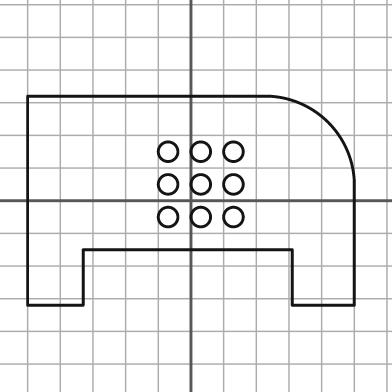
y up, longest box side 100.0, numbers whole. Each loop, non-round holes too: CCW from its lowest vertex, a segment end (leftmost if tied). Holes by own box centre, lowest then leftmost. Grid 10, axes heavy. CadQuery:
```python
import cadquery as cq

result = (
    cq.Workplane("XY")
    .moveTo(-50.0, -32.0)
    .lineTo(-33.0, -32.0)
    .lineTo(-33.0, -15.0)
    .lineTo(31.0, -15.0)
    .lineTo(31.0, -32.0)
    .lineTo(50.0, -32.0)
    .lineTo(50.0, 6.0)
    .threePointArc((42.0, 24.0), (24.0, 32.0))
    .lineTo(-50.0, 32.0)
    .close()
    .moveTo(-7.0, -5.0)
    .circle(3.0)
    .moveTo(3.0, -5.0)
    .circle(3.0)
    .moveTo(13.0, -5.0)
    .circle(3.0)
    .moveTo(-7.0, 5.0)
    .circle(3.0)
    .moveTo(3.0, 5.0)
    .circle(3.0)
    .moveTo(13.0, 5.0)
    .circle(3.0)
    .moveTo(-7.0, 15.0)
    .circle(3.0)
    .moveTo(3.0, 15.0)
    .circle(3.0)
    .moveTo(13.0, 15.0)
    .circle(3.0)
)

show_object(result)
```